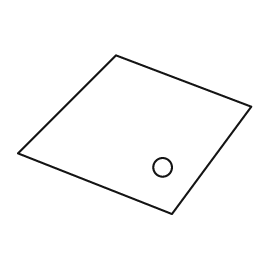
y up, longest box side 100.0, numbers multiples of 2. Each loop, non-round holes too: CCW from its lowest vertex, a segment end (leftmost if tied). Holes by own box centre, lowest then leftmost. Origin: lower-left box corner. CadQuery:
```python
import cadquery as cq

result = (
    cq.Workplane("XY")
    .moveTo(66.0, 0.0)
    .lineTo(100.0, 46.0)
    .lineTo(42.0, 68.0)
    .lineTo(0.0, 26.0)
    .close()
    .moveTo(62.0, 20.0)
    .circle(4.0)
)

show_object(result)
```